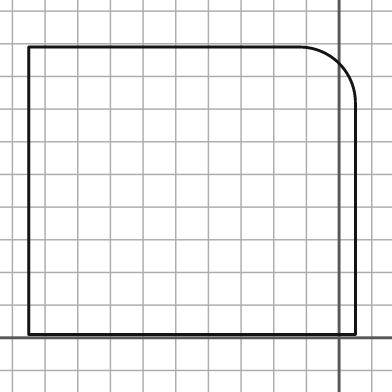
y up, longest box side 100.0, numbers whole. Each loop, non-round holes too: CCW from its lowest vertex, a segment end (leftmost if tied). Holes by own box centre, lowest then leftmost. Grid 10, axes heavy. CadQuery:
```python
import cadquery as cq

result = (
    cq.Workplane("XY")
    .moveTo(-95.0, 1.0)
    .lineTo(5.0, 1.0)
    .lineTo(5.0, 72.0)
    .threePointArc((0.0, 84.0), (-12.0, 89.0))
    .lineTo(-95.0, 89.0)
    .close()
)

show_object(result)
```